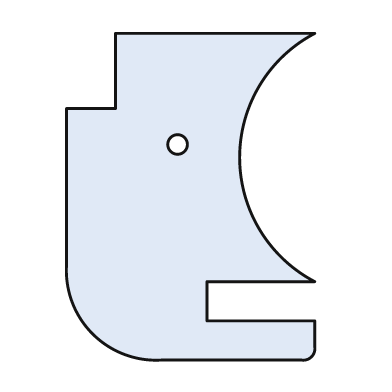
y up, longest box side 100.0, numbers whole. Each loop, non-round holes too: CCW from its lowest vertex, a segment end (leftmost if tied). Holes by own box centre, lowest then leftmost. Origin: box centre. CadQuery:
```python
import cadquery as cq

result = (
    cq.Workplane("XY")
    .moveTo(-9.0, -50.0)
    .lineTo(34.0, -50.0)
    .threePointArc((37.0, -49.0), (38.0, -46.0))
    .lineTo(38.0, -38.0)
    .lineTo(5.0, -38.0)
    .lineTo(5.0, -26.0)
    .lineTo(38.0, -26.0)
    .threePointArc((15.0, 12.0), (38.0, 50.0))
    .lineTo(-23.0, 50.0)
    .lineTo(-23.0, 27.0)
    .lineTo(-38.0, 27.0)
    .lineTo(-38.0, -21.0)
    .threePointArc((-30.0, -42.0), (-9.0, -50.0))
    .close()
    .moveTo(-4.0, 16.0)
    .circle(3.0)
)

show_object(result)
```